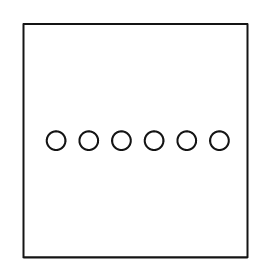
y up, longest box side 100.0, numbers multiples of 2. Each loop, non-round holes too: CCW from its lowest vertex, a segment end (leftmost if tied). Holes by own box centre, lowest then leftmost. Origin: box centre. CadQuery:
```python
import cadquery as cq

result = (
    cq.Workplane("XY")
    .moveTo(-48.0, -50.0)
    .lineTo(48.0, -50.0)
    .lineTo(48.0, 50.0)
    .lineTo(-48.0, 50.0)
    .close()
    .moveTo(-34.0, 0.0)
    .circle(4.0)
    .moveTo(-20.0, 0.0)
    .circle(4.0)
    .moveTo(-6.0, 0.0)
    .circle(4.0)
    .moveTo(8.0, 0.0)
    .circle(4.0)
    .moveTo(22.0, 0.0)
    .circle(4.0)
    .moveTo(36.0, 0.0)
    .circle(4.0)
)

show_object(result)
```